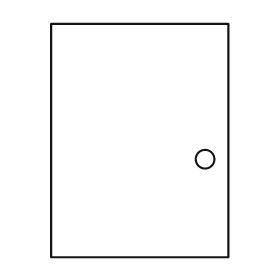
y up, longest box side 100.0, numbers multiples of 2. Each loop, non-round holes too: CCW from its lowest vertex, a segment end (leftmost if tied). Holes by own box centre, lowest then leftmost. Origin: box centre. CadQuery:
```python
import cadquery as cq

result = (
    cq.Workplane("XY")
    .moveTo(-38.0, -50.0)
    .lineTo(38.0, -50.0)
    .lineTo(38.0, 50.0)
    .lineTo(-38.0, 50.0)
    .close()
    .moveTo(28.0, -8.0)
    .circle(4.0)
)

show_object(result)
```